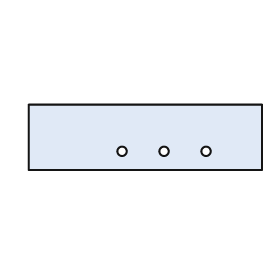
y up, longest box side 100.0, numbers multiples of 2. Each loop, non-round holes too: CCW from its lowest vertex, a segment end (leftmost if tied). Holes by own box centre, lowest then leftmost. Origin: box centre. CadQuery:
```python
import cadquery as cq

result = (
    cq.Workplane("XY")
    .moveTo(-50.0, -14.0)
    .lineTo(50.0, -14.0)
    .lineTo(50.0, 14.0)
    .lineTo(-50.0, 14.0)
    .close()
    .moveTo(-10.0, -6.0)
    .circle(2.0)
    .moveTo(8.0, -6.0)
    .circle(2.0)
    .moveTo(26.0, -6.0)
    .circle(2.0)
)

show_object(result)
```